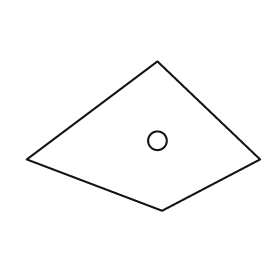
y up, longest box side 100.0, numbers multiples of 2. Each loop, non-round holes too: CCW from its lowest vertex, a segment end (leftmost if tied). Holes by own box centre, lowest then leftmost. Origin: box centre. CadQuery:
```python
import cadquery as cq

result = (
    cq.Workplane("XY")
    .moveTo(8.0, -32.0)
    .lineTo(50.0, -10.0)
    .lineTo(6.0, 32.0)
    .lineTo(-50.0, -10.0)
    .close()
    .moveTo(6.0, -2.0)
    .circle(4.0)
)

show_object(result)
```